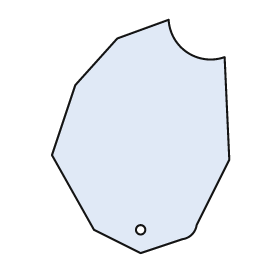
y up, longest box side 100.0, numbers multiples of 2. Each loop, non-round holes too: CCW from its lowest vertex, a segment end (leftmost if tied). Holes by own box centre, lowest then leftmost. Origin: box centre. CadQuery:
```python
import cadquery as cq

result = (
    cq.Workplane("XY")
    .moveTo(0.0, -50.0)
    .lineTo(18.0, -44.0)
    .threePointArc((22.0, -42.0), (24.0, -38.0))
    .lineTo(38.0, -10.0)
    .lineTo(36.0, 34.0)
    .threePointArc((20.0, 36.0), (12.0, 50.0))
    .lineTo(-10.0, 42.0)
    .lineTo(-28.0, 22.0)
    .lineTo(-38.0, -8.0)
    .lineTo(-20.0, -40.0)
    .close()
    .moveTo(0.0, -40.0)
    .circle(2.0)
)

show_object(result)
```